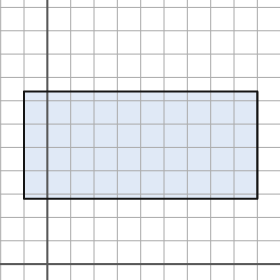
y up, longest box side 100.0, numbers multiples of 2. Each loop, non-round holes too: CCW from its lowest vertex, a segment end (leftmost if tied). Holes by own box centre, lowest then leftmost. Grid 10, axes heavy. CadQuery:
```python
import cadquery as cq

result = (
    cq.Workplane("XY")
    .moveTo(-10.0, 28.0)
    .lineTo(90.0, 28.0)
    .lineTo(90.0, 74.0)
    .lineTo(-10.0, 74.0)
    .close()
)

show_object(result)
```